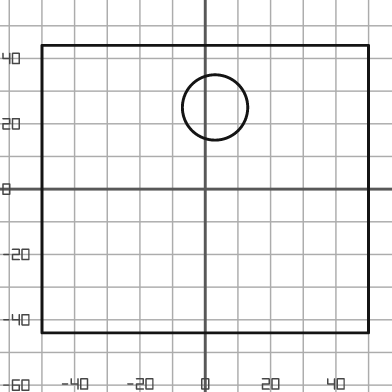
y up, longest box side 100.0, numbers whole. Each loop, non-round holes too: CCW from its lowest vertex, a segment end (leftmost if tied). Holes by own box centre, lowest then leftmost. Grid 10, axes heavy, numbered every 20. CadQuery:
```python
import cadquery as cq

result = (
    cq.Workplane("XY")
    .moveTo(-50.0, -44.0)
    .lineTo(50.0, -44.0)
    .lineTo(50.0, 44.0)
    .lineTo(-50.0, 44.0)
    .close()
    .moveTo(3.0, 25.0)
    .circle(10.0)
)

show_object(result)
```